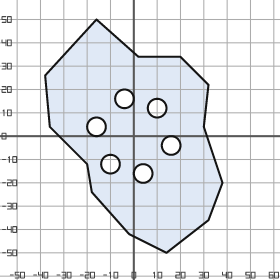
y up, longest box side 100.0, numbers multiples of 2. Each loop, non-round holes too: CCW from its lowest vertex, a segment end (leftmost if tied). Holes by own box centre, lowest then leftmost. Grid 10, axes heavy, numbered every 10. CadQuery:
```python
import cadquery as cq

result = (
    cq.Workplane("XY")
    .moveTo(14.0, -50.0)
    .lineTo(32.0, -36.0)
    .lineTo(38.0, -20.0)
    .lineTo(30.0, 4.0)
    .lineTo(32.0, 22.0)
    .lineTo(20.0, 34.0)
    .lineTo(2.0, 34.0)
    .lineTo(-16.0, 50.0)
    .lineTo(-38.0, 26.0)
    .lineTo(-36.0, 4.0)
    .lineTo(-20.0, -12.0)
    .lineTo(-18.0, -24.0)
    .lineTo(-2.0, -42.0)
    .close()
    .moveTo(4.0, -16.0)
    .circle(4.0)
    .moveTo(-10.0, -12.0)
    .circle(4.0)
    .moveTo(16.0, -4.0)
    .circle(4.0)
    .moveTo(-16.0, 4.0)
    .circle(4.0)
    .moveTo(10.0, 12.0)
    .circle(4.0)
    .moveTo(-4.0, 16.0)
    .circle(4.0)
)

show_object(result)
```